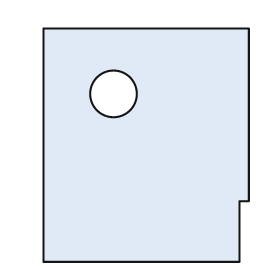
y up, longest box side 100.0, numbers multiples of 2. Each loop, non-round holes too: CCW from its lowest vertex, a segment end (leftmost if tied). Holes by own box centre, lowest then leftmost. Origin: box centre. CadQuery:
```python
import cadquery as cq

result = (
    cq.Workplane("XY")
    .moveTo(-44.0, -50.0)
    .lineTo(40.0, -50.0)
    .lineTo(40.0, -24.0)
    .lineTo(44.0, -24.0)
    .lineTo(44.0, 50.0)
    .lineTo(-44.0, 50.0)
    .close()
    .moveTo(-14.0, 22.0)
    .circle(10.0)
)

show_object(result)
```